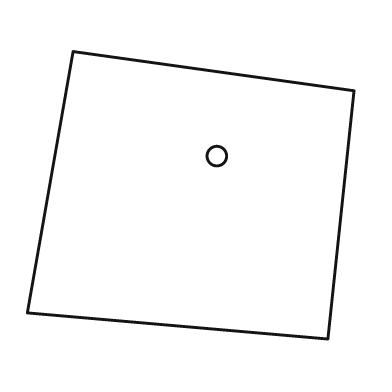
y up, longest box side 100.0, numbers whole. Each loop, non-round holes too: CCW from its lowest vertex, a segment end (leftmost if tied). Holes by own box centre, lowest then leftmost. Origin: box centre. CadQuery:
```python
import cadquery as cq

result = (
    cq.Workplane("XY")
    .moveTo(42.0, -44.0)
    .lineTo(50.0, 32.0)
    .lineTo(-36.0, 44.0)
    .lineTo(-50.0, -36.0)
    .close()
    .moveTo(8.0, 12.0)
    .circle(3.0)
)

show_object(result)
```